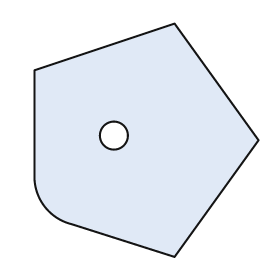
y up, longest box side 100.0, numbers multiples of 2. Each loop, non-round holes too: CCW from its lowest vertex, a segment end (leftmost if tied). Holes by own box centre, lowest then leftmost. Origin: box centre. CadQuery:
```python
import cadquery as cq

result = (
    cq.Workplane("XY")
    .moveTo(12.0, -50.0)
    .lineTo(48.0, 0.0)
    .lineTo(12.0, 50.0)
    .lineTo(-48.0, 30.0)
    .lineTo(-48.0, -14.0)
    .threePointArc((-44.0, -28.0), (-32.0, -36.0))
    .close()
    .moveTo(-14.0, 2.0)
    .circle(6.0)
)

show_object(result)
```